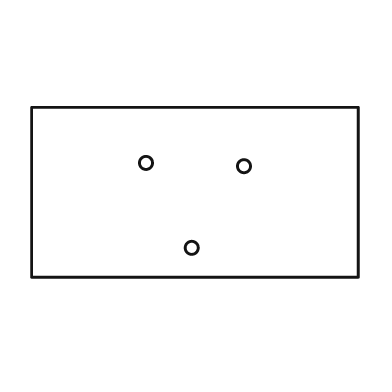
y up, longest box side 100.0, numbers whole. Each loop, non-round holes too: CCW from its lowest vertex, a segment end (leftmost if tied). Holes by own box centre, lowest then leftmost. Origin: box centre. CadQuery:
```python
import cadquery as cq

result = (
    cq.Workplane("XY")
    .moveTo(-50.0, -26.0)
    .lineTo(50.0, -26.0)
    .lineTo(50.0, 26.0)
    .lineTo(-50.0, 26.0)
    .close()
    .moveTo(-1.0, -17.0)
    .circle(2.0)
    .moveTo(15.0, 8.0)
    .circle(2.0)
    .moveTo(-15.0, 9.0)
    .circle(2.0)
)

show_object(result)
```